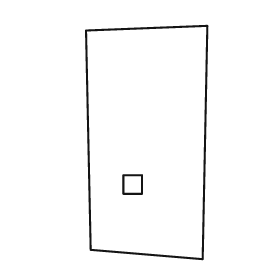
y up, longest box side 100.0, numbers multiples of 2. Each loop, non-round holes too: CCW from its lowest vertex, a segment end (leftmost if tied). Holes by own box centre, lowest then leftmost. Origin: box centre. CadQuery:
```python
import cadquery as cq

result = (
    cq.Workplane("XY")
    .moveTo(24.0, -50.0)
    .lineTo(26.0, 50.0)
    .lineTo(-26.0, 48.0)
    .lineTo(-24.0, -46.0)
    .close()
    .moveTo(-10.0, -22.0)
    .lineTo(-2.0, -22.0)
    .lineTo(-2.0, -14.0)
    .lineTo(-10.0, -14.0)
    .close()
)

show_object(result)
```